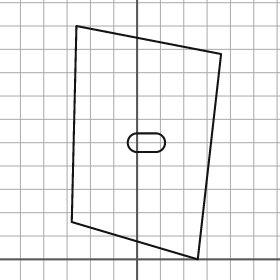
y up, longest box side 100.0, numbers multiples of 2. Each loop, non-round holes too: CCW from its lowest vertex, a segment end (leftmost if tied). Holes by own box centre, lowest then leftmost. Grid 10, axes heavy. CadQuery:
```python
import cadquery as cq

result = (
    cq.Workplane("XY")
    .moveTo(26.0, 0.0)
    .lineTo(36.0, 88.0)
    .lineTo(-26.0, 100.0)
    .lineTo(-28.0, 16.0)
    .close()
    .moveTo(0.0, 46.0)
    .lineTo(8.0, 46.0)
    .threePointArc((12.0, 50.0), (8.0, 54.0))
    .lineTo(0.0, 54.0)
    .threePointArc((-4.0, 50.0), (0.0, 46.0))
    .close()
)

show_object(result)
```